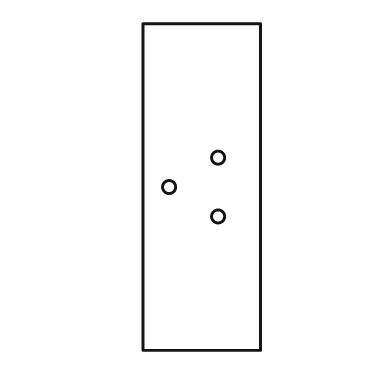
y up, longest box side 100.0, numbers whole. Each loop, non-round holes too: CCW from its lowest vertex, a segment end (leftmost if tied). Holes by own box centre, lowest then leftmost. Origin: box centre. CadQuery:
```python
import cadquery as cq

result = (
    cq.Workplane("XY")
    .moveTo(-18.0, -50.0)
    .lineTo(18.0, -50.0)
    .lineTo(18.0, 50.0)
    .lineTo(-18.0, 50.0)
    .close()
    .moveTo(5.0, -9.0)
    .circle(2.0)
    .moveTo(-10.0, 0.0)
    .circle(2.0)
    .moveTo(5.0, 9.0)
    .circle(2.0)
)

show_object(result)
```